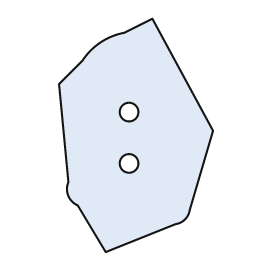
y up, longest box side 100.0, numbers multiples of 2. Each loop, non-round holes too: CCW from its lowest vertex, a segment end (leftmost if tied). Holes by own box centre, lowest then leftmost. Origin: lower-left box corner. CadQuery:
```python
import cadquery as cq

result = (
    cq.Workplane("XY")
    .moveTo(20.0, 0.0)
    .lineTo(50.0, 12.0)
    .threePointArc((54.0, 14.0), (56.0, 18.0))
    .lineTo(66.0, 52.0)
    .lineTo(40.0, 100.0)
    .lineTo(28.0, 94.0)
    .threePointArc((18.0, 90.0), (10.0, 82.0))
    .lineTo(0.0, 72.0)
    .lineTo(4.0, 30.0)
    .threePointArc((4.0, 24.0), (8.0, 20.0))
    .close()
    .moveTo(30.0, 38.0)
    .circle(4.0)
    .moveTo(30.0, 60.0)
    .circle(4.0)
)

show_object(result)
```